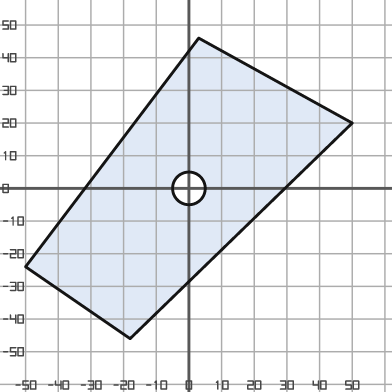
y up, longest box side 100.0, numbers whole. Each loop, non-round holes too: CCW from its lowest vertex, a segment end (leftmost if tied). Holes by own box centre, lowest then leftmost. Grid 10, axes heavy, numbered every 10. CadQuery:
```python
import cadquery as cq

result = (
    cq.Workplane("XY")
    .moveTo(-18.0, -46.0)
    .lineTo(50.0, 20.0)
    .lineTo(3.0, 46.0)
    .lineTo(-50.0, -24.0)
    .close()
    .moveTo(0.0, 0.0)
    .circle(5.0)
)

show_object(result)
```